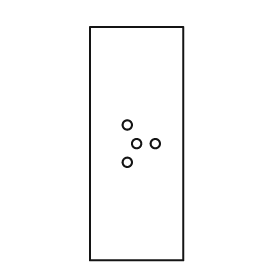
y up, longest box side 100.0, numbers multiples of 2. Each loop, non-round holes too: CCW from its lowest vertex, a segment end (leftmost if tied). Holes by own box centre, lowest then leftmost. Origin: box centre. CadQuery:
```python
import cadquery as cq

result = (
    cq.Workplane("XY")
    .moveTo(-20.0, -50.0)
    .lineTo(20.0, -50.0)
    .lineTo(20.0, 50.0)
    .lineTo(-20.0, 50.0)
    .close()
    .moveTo(-4.0, -8.0)
    .circle(2.0)
    .moveTo(0.0, 0.0)
    .circle(2.0)
    .moveTo(8.0, 0.0)
    .circle(2.0)
    .moveTo(-4.0, 8.0)
    .circle(2.0)
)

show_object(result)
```